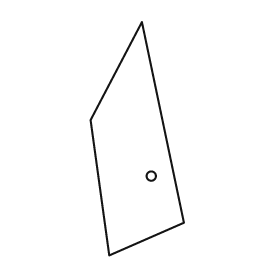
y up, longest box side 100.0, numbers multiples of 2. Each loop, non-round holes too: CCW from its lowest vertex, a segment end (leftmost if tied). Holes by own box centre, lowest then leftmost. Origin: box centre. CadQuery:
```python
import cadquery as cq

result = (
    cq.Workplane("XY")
    .moveTo(-12.0, -50.0)
    .lineTo(20.0, -36.0)
    .lineTo(2.0, 50.0)
    .lineTo(-20.0, 8.0)
    .close()
    .moveTo(6.0, -16.0)
    .circle(2.0)
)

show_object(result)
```